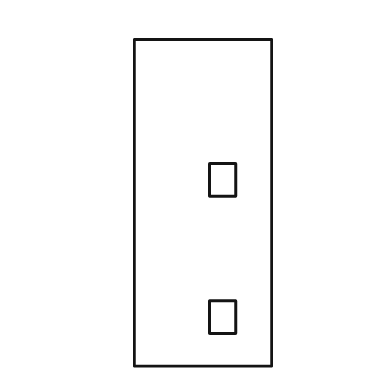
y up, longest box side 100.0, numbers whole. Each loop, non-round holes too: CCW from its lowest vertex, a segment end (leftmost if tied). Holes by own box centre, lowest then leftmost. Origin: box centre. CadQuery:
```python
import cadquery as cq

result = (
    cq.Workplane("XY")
    .moveTo(-21.0, -50.0)
    .lineTo(21.0, -50.0)
    .lineTo(21.0, 50.0)
    .lineTo(-21.0, 50.0)
    .close()
    .moveTo(2.0, -40.0)
    .lineTo(10.0, -40.0)
    .lineTo(10.0, -30.0)
    .lineTo(2.0, -30.0)
    .close()
    .moveTo(2.0, 2.0)
    .lineTo(10.0, 2.0)
    .lineTo(10.0, 12.0)
    .lineTo(2.0, 12.0)
    .close()
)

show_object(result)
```